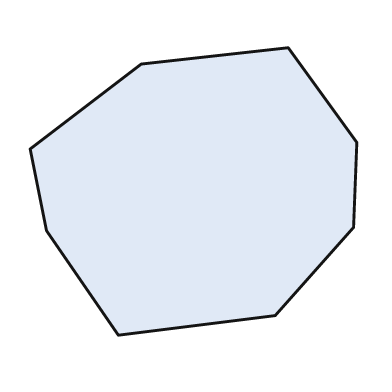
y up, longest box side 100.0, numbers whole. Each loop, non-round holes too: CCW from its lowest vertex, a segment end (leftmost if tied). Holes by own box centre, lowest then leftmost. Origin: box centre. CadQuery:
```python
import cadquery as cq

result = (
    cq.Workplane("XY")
    .moveTo(-23.0, -44.0)
    .lineTo(25.0, -38.0)
    .lineTo(49.0, -11.0)
    .lineTo(50.0, 15.0)
    .lineTo(29.0, 44.0)
    .lineTo(-16.0, 39.0)
    .lineTo(-50.0, 13.0)
    .lineTo(-45.0, -12.0)
    .close()
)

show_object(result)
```